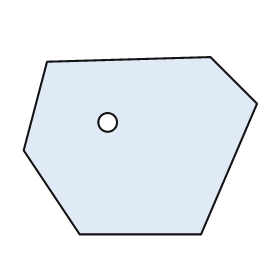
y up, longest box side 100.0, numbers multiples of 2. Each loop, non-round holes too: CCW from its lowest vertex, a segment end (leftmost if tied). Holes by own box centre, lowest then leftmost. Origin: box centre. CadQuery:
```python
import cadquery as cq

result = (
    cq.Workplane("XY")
    .moveTo(-26.0, -38.0)
    .lineTo(26.0, -38.0)
    .lineTo(50.0, 18.0)
    .lineTo(30.0, 38.0)
    .lineTo(-40.0, 36.0)
    .lineTo(-50.0, -2.0)
    .close()
    .moveTo(-14.0, 10.0)
    .circle(4.0)
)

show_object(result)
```